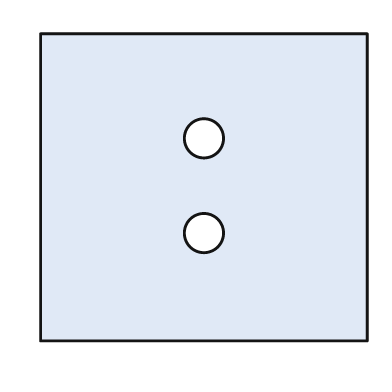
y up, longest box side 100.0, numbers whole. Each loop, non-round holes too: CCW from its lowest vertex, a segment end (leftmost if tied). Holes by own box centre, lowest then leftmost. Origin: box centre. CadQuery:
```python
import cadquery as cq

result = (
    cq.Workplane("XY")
    .moveTo(-50.0, -47.0)
    .lineTo(50.0, -47.0)
    .lineTo(50.0, 47.0)
    .lineTo(-50.0, 47.0)
    .close()
    .moveTo(0.0, -14.0)
    .circle(6.0)
    .moveTo(0.0, 15.0)
    .circle(6.0)
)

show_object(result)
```